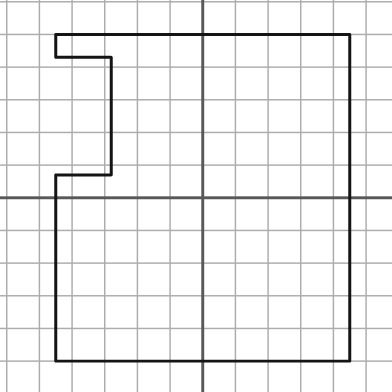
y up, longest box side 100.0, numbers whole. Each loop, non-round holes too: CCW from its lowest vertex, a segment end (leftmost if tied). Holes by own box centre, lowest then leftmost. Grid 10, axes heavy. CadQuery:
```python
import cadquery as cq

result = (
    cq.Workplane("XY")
    .moveTo(-45.0, -50.0)
    .lineTo(45.0, -50.0)
    .lineTo(45.0, 50.0)
    .lineTo(-45.0, 50.0)
    .lineTo(-45.0, 43.0)
    .lineTo(-28.0, 43.0)
    .lineTo(-28.0, 7.0)
    .lineTo(-45.0, 7.0)
    .close()
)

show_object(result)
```